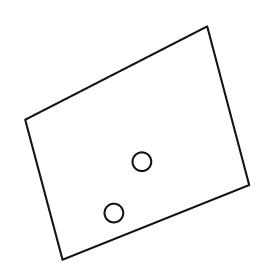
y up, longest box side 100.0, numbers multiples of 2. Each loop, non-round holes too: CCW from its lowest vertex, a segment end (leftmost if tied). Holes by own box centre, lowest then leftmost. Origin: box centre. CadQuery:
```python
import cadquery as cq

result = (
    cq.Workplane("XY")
    .moveTo(-32.0, -50.0)
    .lineTo(48.0, -18.0)
    .lineTo(30.0, 50.0)
    .lineTo(-48.0, 10.0)
    .close()
    .moveTo(-10.0, -30.0)
    .circle(4.0)
    .moveTo(2.0, -8.0)
    .circle(4.0)
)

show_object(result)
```